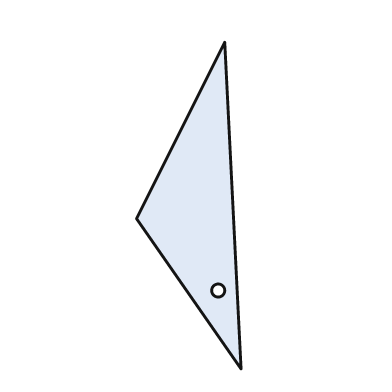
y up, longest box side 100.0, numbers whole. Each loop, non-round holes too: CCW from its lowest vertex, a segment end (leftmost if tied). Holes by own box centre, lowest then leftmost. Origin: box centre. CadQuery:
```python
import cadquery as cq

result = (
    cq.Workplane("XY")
    .moveTo(16.0, -50.0)
    .lineTo(11.0, 50.0)
    .lineTo(-16.0, -4.0)
    .close()
    .moveTo(9.0, -26.0)
    .circle(2.0)
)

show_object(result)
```